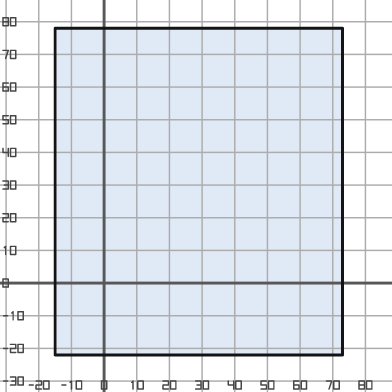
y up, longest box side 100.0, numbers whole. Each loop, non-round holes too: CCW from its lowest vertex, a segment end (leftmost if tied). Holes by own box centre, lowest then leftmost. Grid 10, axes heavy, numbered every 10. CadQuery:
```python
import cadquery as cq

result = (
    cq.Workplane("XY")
    .moveTo(-15.0, -22.0)
    .lineTo(73.0, -22.0)
    .lineTo(73.0, 78.0)
    .lineTo(-15.0, 78.0)
    .close()
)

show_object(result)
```